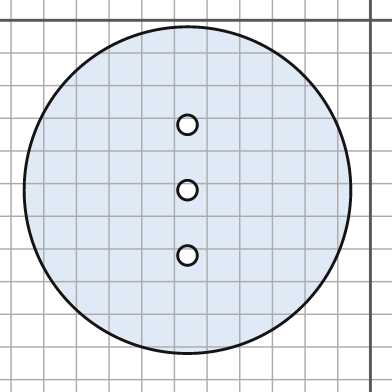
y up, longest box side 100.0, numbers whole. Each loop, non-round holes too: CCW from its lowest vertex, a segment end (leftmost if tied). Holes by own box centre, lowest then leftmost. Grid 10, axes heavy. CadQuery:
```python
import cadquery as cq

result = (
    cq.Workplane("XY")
    .moveTo(-56.0, -52.0)
    .circle(50.0)
    .moveTo(-56.0, -72.0)
    .circle(3.0)
    .moveTo(-56.0, -52.0)
    .circle(3.0)
    .moveTo(-56.0, -32.0)
    .circle(3.0)
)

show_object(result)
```